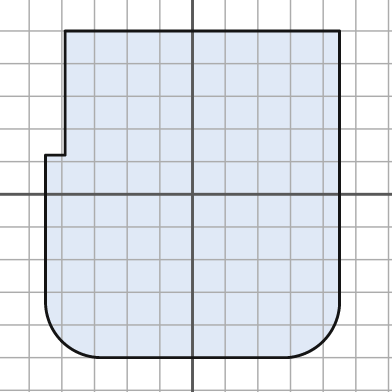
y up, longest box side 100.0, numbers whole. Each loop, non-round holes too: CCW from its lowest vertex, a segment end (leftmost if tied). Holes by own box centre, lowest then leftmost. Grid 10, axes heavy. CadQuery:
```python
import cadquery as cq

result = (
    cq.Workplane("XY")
    .moveTo(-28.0, -50.0)
    .lineTo(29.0, -50.0)
    .threePointArc((40.0, -45.0), (45.0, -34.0))
    .lineTo(45.0, 50.0)
    .lineTo(-39.0, 50.0)
    .lineTo(-39.0, 12.0)
    .lineTo(-45.0, 12.0)
    .lineTo(-45.0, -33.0)
    .threePointArc((-40.0, -45.0), (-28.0, -50.0))
    .close()
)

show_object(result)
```